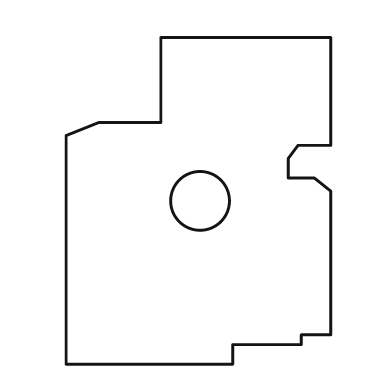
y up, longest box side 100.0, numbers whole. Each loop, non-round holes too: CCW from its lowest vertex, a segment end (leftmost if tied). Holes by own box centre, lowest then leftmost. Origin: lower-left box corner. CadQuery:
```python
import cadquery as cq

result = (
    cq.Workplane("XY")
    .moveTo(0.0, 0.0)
    .lineTo(51.0, 0.0)
    .lineTo(51.0, 6.0)
    .lineTo(72.0, 6.0)
    .lineTo(72.0, 9.0)
    .lineTo(81.0, 9.0)
    .lineTo(81.0, 53.0)
    .lineTo(76.0, 57.0)
    .lineTo(68.0, 57.0)
    .lineTo(68.0, 63.0)
    .lineTo(71.0, 67.0)
    .lineTo(81.0, 67.0)
    .lineTo(81.0, 100.0)
    .lineTo(29.0, 100.0)
    .lineTo(29.0, 74.0)
    .lineTo(10.0, 74.0)
    .lineTo(0.0, 70.0)
    .close()
    .moveTo(41.0, 50.0)
    .circle(9.0)
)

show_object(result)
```